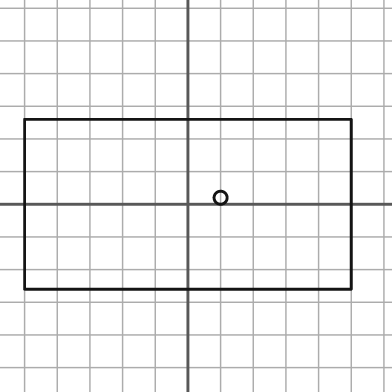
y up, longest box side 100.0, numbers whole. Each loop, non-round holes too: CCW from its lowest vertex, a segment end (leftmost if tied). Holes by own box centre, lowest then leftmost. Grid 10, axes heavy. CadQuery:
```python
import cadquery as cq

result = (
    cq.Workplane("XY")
    .moveTo(-50.0, -26.0)
    .lineTo(50.0, -26.0)
    .lineTo(50.0, 26.0)
    .lineTo(-50.0, 26.0)
    .close()
    .moveTo(10.0, 2.0)
    .circle(2.0)
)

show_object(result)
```